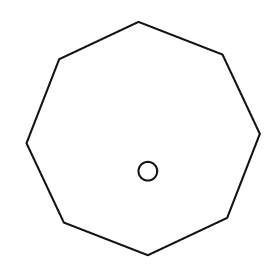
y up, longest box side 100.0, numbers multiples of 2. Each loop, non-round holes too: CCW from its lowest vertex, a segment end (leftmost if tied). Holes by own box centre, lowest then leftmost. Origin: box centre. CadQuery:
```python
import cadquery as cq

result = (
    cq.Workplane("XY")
    .moveTo(2.0, -50.0)
    .lineTo(36.0, -34.0)
    .lineTo(50.0, 2.0)
    .lineTo(34.0, 36.0)
    .lineTo(-2.0, 50.0)
    .lineTo(-36.0, 34.0)
    .lineTo(-50.0, -2.0)
    .lineTo(-34.0, -36.0)
    .close()
    .moveTo(2.0, -14.0)
    .circle(4.0)
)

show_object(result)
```